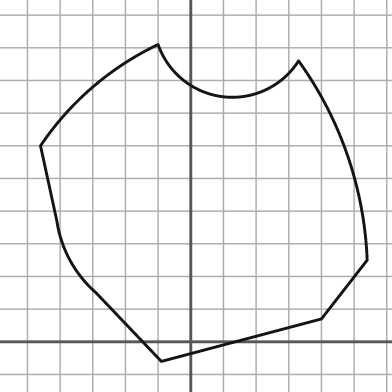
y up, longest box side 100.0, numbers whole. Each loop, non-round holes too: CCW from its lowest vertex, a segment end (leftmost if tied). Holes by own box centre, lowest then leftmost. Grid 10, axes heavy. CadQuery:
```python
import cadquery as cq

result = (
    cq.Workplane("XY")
    .moveTo(-9.0, -6.0)
    .lineTo(40.0, 7.0)
    .lineTo(54.0, 25.0)
    .threePointArc((48.0, 57.0), (33.0, 86.0))
    .threePointArc((10.0, 75.0), (-10.0, 91.0))
    .threePointArc((-30.0, 78.0), (-46.0, 60.0))
    .lineTo(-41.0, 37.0)
    .threePointArc((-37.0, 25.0), (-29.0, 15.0))
    .close()
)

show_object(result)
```